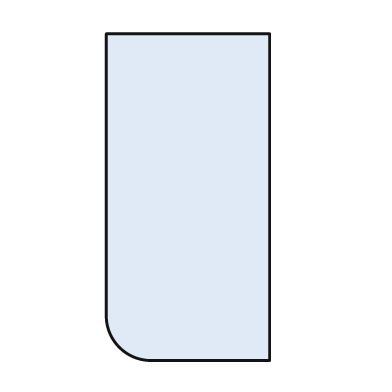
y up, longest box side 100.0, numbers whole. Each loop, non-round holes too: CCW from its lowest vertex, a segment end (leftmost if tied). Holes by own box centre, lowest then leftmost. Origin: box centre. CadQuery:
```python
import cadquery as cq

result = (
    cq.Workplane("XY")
    .moveTo(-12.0, -50.0)
    .lineTo(25.0, -50.0)
    .lineTo(25.0, 50.0)
    .lineTo(-25.0, 50.0)
    .lineTo(-25.0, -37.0)
    .threePointArc((-21.0, -46.0), (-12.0, -50.0))
    .close()
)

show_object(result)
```